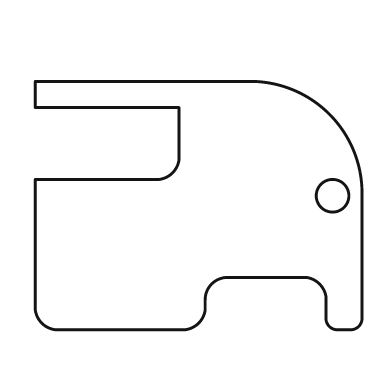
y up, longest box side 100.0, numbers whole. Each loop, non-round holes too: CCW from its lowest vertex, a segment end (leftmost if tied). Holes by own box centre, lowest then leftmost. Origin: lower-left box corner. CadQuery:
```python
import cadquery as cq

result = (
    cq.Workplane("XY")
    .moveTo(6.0, 0.0)
    .lineTo(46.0, 0.0)
    .threePointArc((50.0, 2.0), (52.0, 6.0))
    .lineTo(52.0, 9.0)
    .threePointArc((54.0, 14.0), (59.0, 16.0))
    .lineTo(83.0, 16.0)
    .threePointArc((87.0, 14.0), (89.0, 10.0))
    .lineTo(89.0, 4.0)
    .threePointArc((90.0, 1.0), (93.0, 0.0))
    .lineTo(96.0, 0.0)
    .threePointArc((99.0, 1.0), (100.0, 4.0))
    .lineTo(100.0, 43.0)
    .threePointArc((90.0, 66.0), (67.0, 76.0))
    .lineTo(0.0, 76.0)
    .lineTo(0.0, 68.0)
    .lineTo(44.0, 68.0)
    .lineTo(44.0, 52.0)
    .threePointArc((42.0, 48.0), (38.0, 46.0))
    .lineTo(0.0, 46.0)
    .lineTo(0.0, 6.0)
    .threePointArc((2.0, 2.0), (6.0, 0.0))
    .close()
    .moveTo(91.0, 41.0)
    .circle(5.0)
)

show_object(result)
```